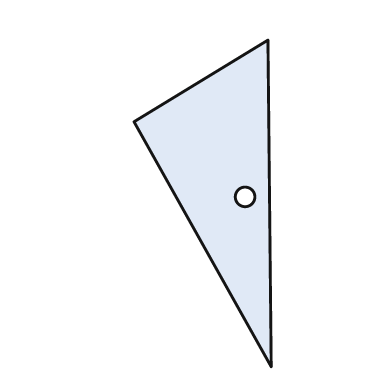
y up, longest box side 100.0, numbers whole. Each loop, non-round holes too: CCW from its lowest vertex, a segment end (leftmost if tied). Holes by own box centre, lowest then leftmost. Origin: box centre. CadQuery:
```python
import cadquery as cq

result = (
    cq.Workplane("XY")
    .moveTo(21.0, -50.0)
    .lineTo(20.0, 50.0)
    .lineTo(-21.0, 25.0)
    .close()
    .moveTo(13.0, 2.0)
    .circle(3.0)
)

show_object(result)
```